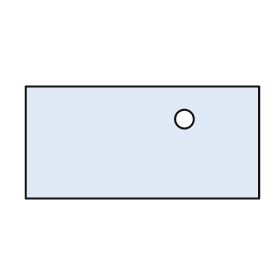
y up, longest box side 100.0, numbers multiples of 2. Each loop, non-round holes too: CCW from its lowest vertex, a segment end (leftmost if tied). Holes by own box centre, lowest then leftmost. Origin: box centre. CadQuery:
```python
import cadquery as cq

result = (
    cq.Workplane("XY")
    .moveTo(-50.0, -24.0)
    .lineTo(50.0, -24.0)
    .lineTo(50.0, 24.0)
    .lineTo(-50.0, 24.0)
    .close()
    .moveTo(18.0, 10.0)
    .circle(4.0)
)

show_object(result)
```